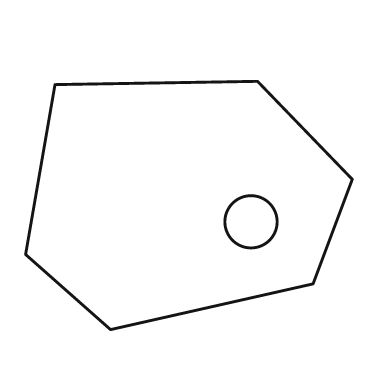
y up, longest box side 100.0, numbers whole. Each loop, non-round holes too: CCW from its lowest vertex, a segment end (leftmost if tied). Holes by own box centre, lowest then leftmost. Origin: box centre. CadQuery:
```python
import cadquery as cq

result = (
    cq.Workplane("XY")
    .moveTo(-24.0, -38.0)
    .lineTo(38.0, -24.0)
    .lineTo(50.0, 8.0)
    .lineTo(21.0, 38.0)
    .lineTo(-41.0, 37.0)
    .lineTo(-50.0, -15.0)
    .close()
    .moveTo(19.0, -5.0)
    .circle(8.0)
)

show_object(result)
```